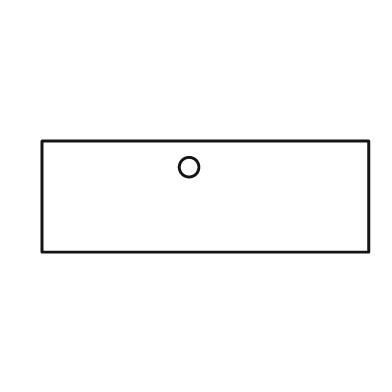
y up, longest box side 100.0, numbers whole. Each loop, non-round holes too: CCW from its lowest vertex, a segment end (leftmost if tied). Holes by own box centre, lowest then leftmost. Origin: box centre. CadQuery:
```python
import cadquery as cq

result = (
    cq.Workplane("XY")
    .moveTo(-50.0, -17.0)
    .lineTo(50.0, -17.0)
    .lineTo(50.0, 17.0)
    .lineTo(-50.0, 17.0)
    .close()
    .moveTo(-5.0, 9.0)
    .circle(3.0)
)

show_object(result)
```